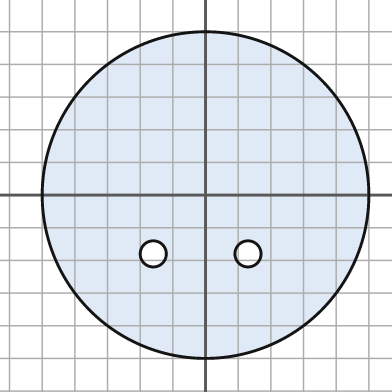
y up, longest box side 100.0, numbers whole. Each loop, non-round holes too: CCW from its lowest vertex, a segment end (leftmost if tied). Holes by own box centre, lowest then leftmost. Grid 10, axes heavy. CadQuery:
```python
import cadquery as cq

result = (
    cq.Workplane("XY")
    .moveTo(0.0, 0.0)
    .circle(50.0)
    .moveTo(-16.0, -18.0)
    .circle(4.0)
    .moveTo(13.0, -18.0)
    .circle(4.0)
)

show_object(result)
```